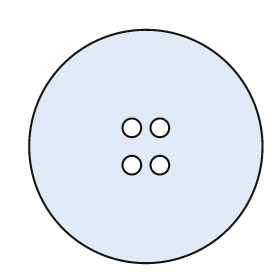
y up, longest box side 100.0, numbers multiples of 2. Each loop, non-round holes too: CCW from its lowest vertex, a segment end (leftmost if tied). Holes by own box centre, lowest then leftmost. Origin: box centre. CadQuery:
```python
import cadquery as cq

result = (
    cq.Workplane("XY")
    .moveTo(0.0, 0.0)
    .circle(50.0)
    .moveTo(-6.0, -8.0)
    .circle(4.0)
    .moveTo(6.0, -8.0)
    .circle(4.0)
    .moveTo(-6.0, 8.0)
    .circle(4.0)
    .moveTo(6.0, 8.0)
    .circle(4.0)
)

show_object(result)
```